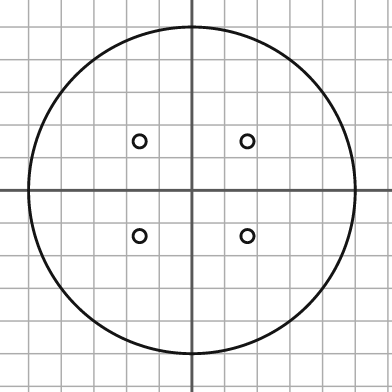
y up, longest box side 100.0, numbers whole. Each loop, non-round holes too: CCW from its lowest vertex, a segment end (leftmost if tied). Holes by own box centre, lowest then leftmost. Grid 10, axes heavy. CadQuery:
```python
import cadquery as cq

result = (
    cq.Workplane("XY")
    .moveTo(0.0, 0.0)
    .circle(50.0)
    .moveTo(-16.0, -14.0)
    .circle(2.0)
    .moveTo(17.0, -14.0)
    .circle(2.0)
    .moveTo(-16.0, 15.0)
    .circle(2.0)
    .moveTo(17.0, 15.0)
    .circle(2.0)
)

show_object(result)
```